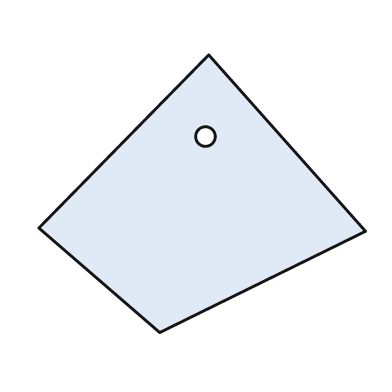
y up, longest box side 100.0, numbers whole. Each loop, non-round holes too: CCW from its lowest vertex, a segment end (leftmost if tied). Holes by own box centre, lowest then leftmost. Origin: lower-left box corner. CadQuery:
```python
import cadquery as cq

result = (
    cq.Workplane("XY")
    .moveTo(37.0, 0.0)
    .lineTo(100.0, 31.0)
    .lineTo(52.0, 85.0)
    .lineTo(0.0, 32.0)
    .close()
    .moveTo(51.0, 60.0)
    .circle(3.0)
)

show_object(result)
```